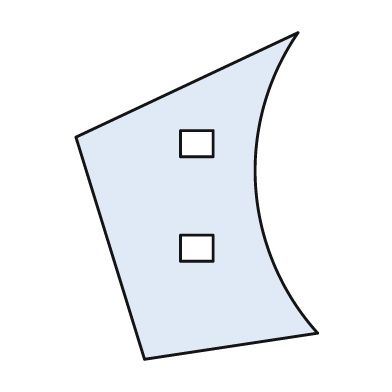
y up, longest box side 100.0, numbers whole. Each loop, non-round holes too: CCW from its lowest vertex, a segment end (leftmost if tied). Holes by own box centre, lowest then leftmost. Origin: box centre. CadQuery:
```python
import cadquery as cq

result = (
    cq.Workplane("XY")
    .moveTo(-16.0, -50.0)
    .lineTo(37.0, -42.0)
    .threePointArc((18.0, 3.0), (31.0, 50.0))
    .lineTo(-37.0, 18.0)
    .close()
    .moveTo(-5.0, -20.0)
    .lineTo(5.0, -20.0)
    .lineTo(5.0, -12.0)
    .lineTo(-5.0, -12.0)
    .close()
    .moveTo(-5.0, 12.0)
    .lineTo(5.0, 12.0)
    .lineTo(5.0, 20.0)
    .lineTo(-5.0, 20.0)
    .close()
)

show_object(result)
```